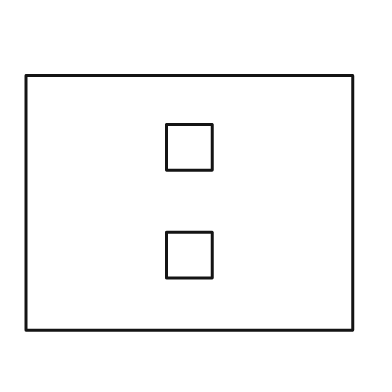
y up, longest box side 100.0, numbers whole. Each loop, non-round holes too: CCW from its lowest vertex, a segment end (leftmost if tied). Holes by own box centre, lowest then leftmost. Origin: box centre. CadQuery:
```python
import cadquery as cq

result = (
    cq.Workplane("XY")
    .moveTo(-50.0, -39.0)
    .lineTo(50.0, -39.0)
    .lineTo(50.0, 39.0)
    .lineTo(-50.0, 39.0)
    .close()
    .moveTo(-7.0, -23.0)
    .lineTo(7.0, -23.0)
    .lineTo(7.0, -9.0)
    .lineTo(-7.0, -9.0)
    .close()
    .moveTo(-7.0, 10.0)
    .lineTo(7.0, 10.0)
    .lineTo(7.0, 24.0)
    .lineTo(-7.0, 24.0)
    .close()
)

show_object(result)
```